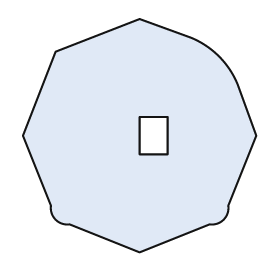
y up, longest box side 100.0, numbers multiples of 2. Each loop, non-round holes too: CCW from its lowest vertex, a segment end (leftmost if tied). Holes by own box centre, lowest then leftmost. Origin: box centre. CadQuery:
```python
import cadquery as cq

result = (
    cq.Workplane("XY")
    .moveTo(0.0, -50.0)
    .lineTo(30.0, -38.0)
    .threePointArc((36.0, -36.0), (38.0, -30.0))
    .lineTo(50.0, 0.0)
    .lineTo(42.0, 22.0)
    .threePointArc((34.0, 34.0), (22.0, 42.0))
    .lineTo(0.0, 50.0)
    .lineTo(-36.0, 36.0)
    .lineTo(-50.0, 0.0)
    .lineTo(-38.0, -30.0)
    .threePointArc((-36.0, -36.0), (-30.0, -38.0))
    .close()
    .moveTo(0.0, -8.0)
    .lineTo(12.0, -8.0)
    .lineTo(12.0, 8.0)
    .lineTo(0.0, 8.0)
    .close()
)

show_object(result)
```